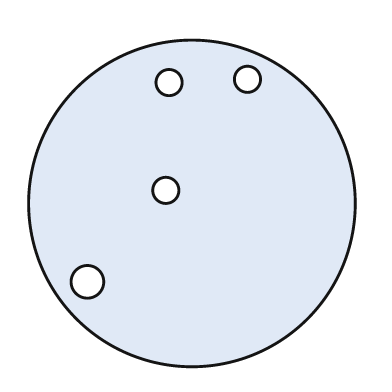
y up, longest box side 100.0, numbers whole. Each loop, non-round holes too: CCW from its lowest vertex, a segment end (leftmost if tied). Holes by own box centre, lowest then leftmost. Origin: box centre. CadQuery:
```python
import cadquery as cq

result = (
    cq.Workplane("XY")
    .moveTo(0.0, 0.0)
    .circle(50.0)
    .moveTo(-32.0, -24.0)
    .circle(5.0)
    .moveTo(-8.0, 4.0)
    .circle(4.0)
    .moveTo(-7.0, 37.0)
    .circle(4.0)
    .moveTo(17.0, 38.0)
    .circle(4.0)
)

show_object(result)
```